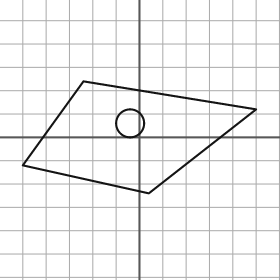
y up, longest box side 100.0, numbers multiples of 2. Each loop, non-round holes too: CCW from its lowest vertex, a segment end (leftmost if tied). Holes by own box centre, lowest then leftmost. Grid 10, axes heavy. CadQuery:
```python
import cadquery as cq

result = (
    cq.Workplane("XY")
    .moveTo(4.0, -24.0)
    .lineTo(50.0, 12.0)
    .lineTo(-24.0, 24.0)
    .lineTo(-50.0, -12.0)
    .close()
    .moveTo(-4.0, 6.0)
    .circle(6.0)
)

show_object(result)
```